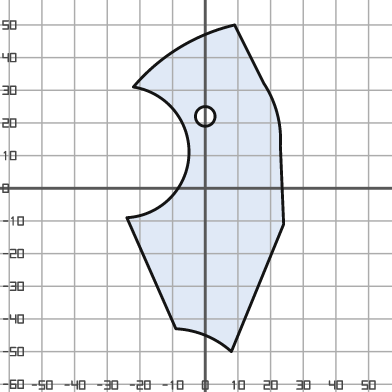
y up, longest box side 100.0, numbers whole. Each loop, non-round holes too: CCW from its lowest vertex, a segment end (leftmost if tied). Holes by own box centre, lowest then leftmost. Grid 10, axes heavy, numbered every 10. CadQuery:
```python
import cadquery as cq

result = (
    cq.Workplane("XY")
    .moveTo(8.0, -50.0)
    .lineTo(24.0, -11.0)
    .lineTo(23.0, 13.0)
    .threePointArc((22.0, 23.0), (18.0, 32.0))
    .lineTo(9.0, 50.0)
    .threePointArc((-8.0, 43.0), (-22.0, 31.0))
    .threePointArc((-5.0, 10.0), (-24.0, -9.0))
    .lineTo(-9.0, -43.0)
    .threePointArc((0.0, -45.0), (8.0, -50.0))
    .close()
    .moveTo(0.0, 22.0)
    .circle(3.0)
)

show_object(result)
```